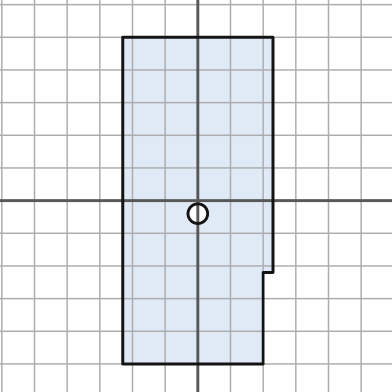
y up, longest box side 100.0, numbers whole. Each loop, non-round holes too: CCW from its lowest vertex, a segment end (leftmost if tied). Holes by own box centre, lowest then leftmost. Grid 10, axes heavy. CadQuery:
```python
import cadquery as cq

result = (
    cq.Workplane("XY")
    .moveTo(-23.0, -50.0)
    .lineTo(20.0, -50.0)
    .lineTo(20.0, -22.0)
    .lineTo(23.0, -22.0)
    .lineTo(23.0, 50.0)
    .lineTo(-23.0, 50.0)
    .close()
    .moveTo(0.0, -4.0)
    .circle(3.0)
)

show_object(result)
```